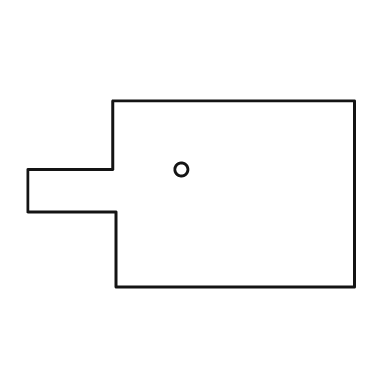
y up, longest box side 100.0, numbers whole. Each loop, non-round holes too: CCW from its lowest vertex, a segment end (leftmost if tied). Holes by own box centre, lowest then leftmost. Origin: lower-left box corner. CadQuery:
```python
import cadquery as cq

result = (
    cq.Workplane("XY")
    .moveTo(27.0, 0.0)
    .lineTo(100.0, 0.0)
    .lineTo(100.0, 57.0)
    .lineTo(26.0, 57.0)
    .lineTo(26.0, 36.0)
    .lineTo(0.0, 36.0)
    .lineTo(0.0, 23.0)
    .lineTo(27.0, 23.0)
    .close()
    .moveTo(47.0, 36.0)
    .circle(2.0)
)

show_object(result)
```